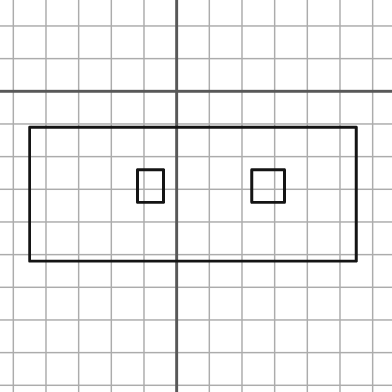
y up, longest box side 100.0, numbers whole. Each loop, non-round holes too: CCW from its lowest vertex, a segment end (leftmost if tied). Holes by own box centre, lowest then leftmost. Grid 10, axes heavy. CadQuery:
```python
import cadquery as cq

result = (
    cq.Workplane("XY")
    .moveTo(-45.0, -52.0)
    .lineTo(55.0, -52.0)
    .lineTo(55.0, -11.0)
    .lineTo(-45.0, -11.0)
    .close()
    .moveTo(-12.0, -34.0)
    .lineTo(-4.0, -34.0)
    .lineTo(-4.0, -24.0)
    .lineTo(-12.0, -24.0)
    .close()
    .moveTo(23.0, -34.0)
    .lineTo(33.0, -34.0)
    .lineTo(33.0, -24.0)
    .lineTo(23.0, -24.0)
    .close()
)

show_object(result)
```